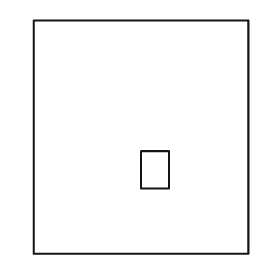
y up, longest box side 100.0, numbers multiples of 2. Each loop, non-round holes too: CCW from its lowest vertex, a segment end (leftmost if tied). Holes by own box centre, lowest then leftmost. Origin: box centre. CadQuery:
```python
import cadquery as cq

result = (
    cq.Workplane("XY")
    .moveTo(-46.0, -50.0)
    .lineTo(46.0, -50.0)
    .lineTo(46.0, 50.0)
    .lineTo(-46.0, 50.0)
    .close()
    .moveTo(0.0, -22.0)
    .lineTo(12.0, -22.0)
    .lineTo(12.0, -6.0)
    .lineTo(0.0, -6.0)
    .close()
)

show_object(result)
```